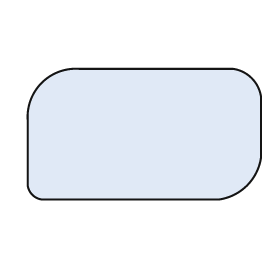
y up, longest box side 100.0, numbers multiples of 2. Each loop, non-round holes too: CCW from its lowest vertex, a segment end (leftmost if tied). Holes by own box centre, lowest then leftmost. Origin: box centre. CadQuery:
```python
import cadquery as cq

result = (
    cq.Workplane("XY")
    .moveTo(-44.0, -28.0)
    .lineTo(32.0, -28.0)
    .threePointArc((44.0, -22.0), (50.0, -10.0))
    .lineTo(50.0, 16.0)
    .threePointArc((46.0, 24.0), (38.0, 28.0))
    .lineTo(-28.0, 28.0)
    .threePointArc((-44.0, 22.0), (-50.0, 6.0))
    .lineTo(-50.0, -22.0)
    .threePointArc((-48.0, -26.0), (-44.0, -28.0))
    .close()
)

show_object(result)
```